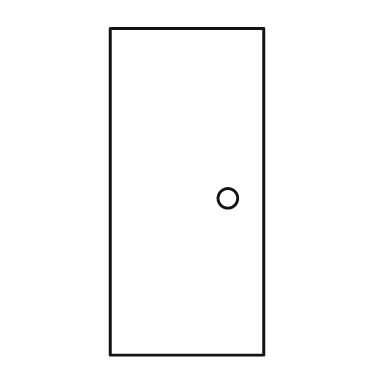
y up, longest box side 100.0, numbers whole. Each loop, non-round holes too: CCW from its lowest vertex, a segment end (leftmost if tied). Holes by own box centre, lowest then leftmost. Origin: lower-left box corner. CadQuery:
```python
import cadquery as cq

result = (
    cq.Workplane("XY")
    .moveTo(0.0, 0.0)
    .lineTo(47.0, 0.0)
    .lineTo(47.0, 100.0)
    .lineTo(0.0, 100.0)
    .close()
    .moveTo(36.0, 48.0)
    .circle(3.0)
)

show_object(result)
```